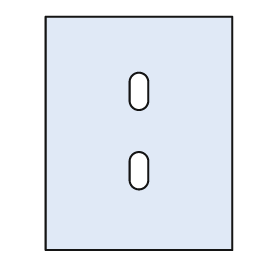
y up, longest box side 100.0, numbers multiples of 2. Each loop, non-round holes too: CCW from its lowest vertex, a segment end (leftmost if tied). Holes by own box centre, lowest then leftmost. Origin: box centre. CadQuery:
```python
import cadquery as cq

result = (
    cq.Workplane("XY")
    .moveTo(-40.0, -50.0)
    .lineTo(40.0, -50.0)
    .lineTo(40.0, 50.0)
    .lineTo(-40.0, 50.0)
    .close()
    .moveTo(-4.0, -20.0)
    .threePointArc((0.0, -24.0), (4.0, -20.0))
    .lineTo(4.0, -12.0)
    .threePointArc((0.0, -8.0), (-4.0, -12.0))
    .close()
    .moveTo(-4.0, 14.0)
    .threePointArc((0.0, 10.0), (4.0, 14.0))
    .lineTo(4.0, 22.0)
    .threePointArc((0.0, 26.0), (-4.0, 22.0))
    .close()
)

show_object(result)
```